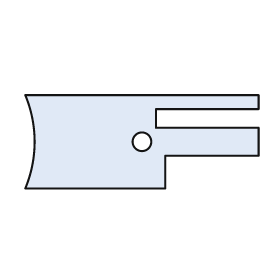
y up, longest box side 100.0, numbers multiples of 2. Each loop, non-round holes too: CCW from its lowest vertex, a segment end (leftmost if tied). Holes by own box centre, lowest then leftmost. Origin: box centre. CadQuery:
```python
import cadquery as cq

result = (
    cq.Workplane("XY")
    .moveTo(-50.0, -20.0)
    .lineTo(10.0, -20.0)
    .lineTo(10.0, -6.0)
    .lineTo(50.0, -6.0)
    .lineTo(50.0, 6.0)
    .lineTo(6.0, 6.0)
    .lineTo(6.0, 14.0)
    .lineTo(50.0, 14.0)
    .lineTo(50.0, 20.0)
    .lineTo(-50.0, 20.0)
    .threePointArc((-46.0, 0.0), (-50.0, -20.0))
    .close()
    .moveTo(0.0, 0.0)
    .circle(4.0)
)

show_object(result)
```